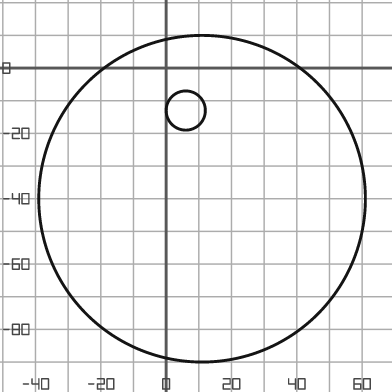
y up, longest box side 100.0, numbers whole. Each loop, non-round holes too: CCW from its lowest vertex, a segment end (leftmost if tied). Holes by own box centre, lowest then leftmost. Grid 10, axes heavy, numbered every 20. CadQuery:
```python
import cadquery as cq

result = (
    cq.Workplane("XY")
    .moveTo(11.0, -40.0)
    .circle(50.0)
    .moveTo(6.0, -13.0)
    .circle(6.0)
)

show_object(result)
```